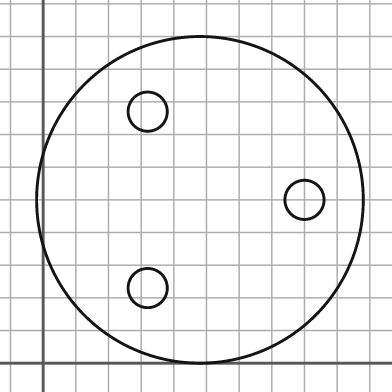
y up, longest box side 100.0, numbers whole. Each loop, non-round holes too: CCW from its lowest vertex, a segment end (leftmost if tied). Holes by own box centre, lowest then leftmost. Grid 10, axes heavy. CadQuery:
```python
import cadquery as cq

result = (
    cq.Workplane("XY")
    .moveTo(48.0, 50.0)
    .circle(50.0)
    .moveTo(32.0, 23.0)
    .circle(6.0)
    .moveTo(80.0, 50.0)
    .circle(6.0)
    .moveTo(32.0, 77.0)
    .circle(6.0)
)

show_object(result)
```